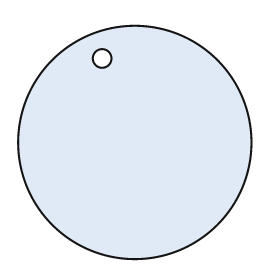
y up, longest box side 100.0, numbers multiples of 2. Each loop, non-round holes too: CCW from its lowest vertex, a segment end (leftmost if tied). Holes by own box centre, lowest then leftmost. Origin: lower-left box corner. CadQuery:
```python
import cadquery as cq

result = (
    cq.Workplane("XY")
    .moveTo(50.0, 50.0)
    .circle(50.0)
    .moveTo(36.0, 86.0)
    .circle(4.0)
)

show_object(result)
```